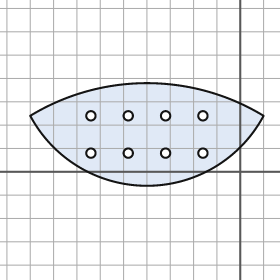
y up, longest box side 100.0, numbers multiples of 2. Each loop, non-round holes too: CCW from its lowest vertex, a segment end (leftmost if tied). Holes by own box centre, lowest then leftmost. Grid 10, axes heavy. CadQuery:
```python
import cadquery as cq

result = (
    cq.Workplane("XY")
    .moveTo(-90.0, 24.0)
    .threePointArc((-40.0, -6.0), (10.0, 24.0))
    .threePointArc((-40.0, 38.0), (-90.0, 24.0))
    .close()
    .moveTo(-64.0, 8.0)
    .circle(2.0)
    .moveTo(-48.0, 8.0)
    .circle(2.0)
    .moveTo(-32.0, 8.0)
    .circle(2.0)
    .moveTo(-16.0, 8.0)
    .circle(2.0)
    .moveTo(-64.0, 24.0)
    .circle(2.0)
    .moveTo(-48.0, 24.0)
    .circle(2.0)
    .moveTo(-32.0, 24.0)
    .circle(2.0)
    .moveTo(-16.0, 24.0)
    .circle(2.0)
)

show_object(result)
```